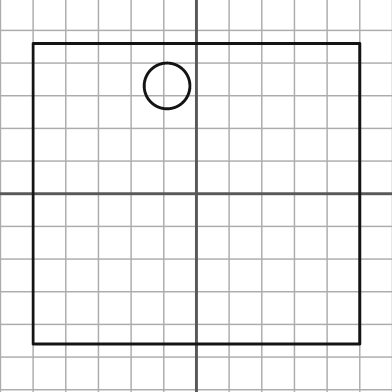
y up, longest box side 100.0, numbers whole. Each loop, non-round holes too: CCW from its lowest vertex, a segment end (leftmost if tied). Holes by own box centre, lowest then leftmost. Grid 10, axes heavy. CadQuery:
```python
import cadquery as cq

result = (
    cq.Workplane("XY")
    .moveTo(-50.0, -46.0)
    .lineTo(50.0, -46.0)
    .lineTo(50.0, 46.0)
    .lineTo(-50.0, 46.0)
    .close()
    .moveTo(-9.0, 33.0)
    .circle(7.0)
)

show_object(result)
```